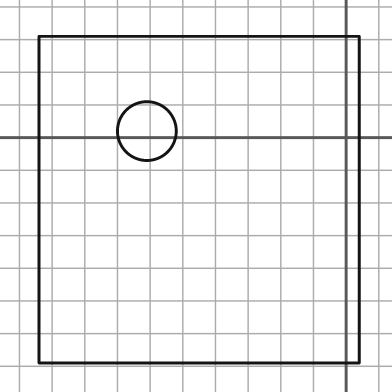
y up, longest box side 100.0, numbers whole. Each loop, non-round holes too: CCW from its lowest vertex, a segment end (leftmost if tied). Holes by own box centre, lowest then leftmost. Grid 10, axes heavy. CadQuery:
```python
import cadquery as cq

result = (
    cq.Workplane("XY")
    .moveTo(-94.0, -69.0)
    .lineTo(4.0, -69.0)
    .lineTo(4.0, 31.0)
    .lineTo(-94.0, 31.0)
    .close()
    .moveTo(-61.0, 2.0)
    .circle(9.0)
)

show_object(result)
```